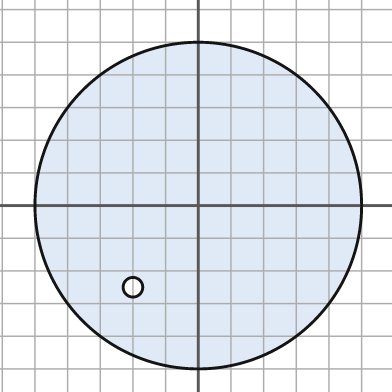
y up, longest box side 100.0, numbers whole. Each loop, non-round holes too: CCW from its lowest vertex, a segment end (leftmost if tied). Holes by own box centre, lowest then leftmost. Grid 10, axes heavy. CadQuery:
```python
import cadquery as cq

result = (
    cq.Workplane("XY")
    .moveTo(0.0, 0.0)
    .circle(50.0)
    .moveTo(-20.0, -25.0)
    .circle(3.0)
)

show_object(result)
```